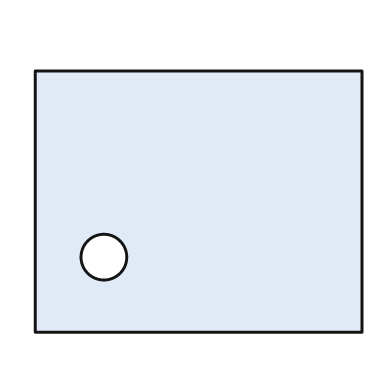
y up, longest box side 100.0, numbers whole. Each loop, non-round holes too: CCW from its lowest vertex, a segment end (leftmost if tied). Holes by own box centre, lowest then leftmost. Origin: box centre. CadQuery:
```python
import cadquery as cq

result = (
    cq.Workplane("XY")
    .moveTo(-50.0, -40.0)
    .lineTo(50.0, -40.0)
    .lineTo(50.0, 40.0)
    .lineTo(-50.0, 40.0)
    .close()
    .moveTo(-29.0, -17.0)
    .circle(7.0)
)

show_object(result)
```